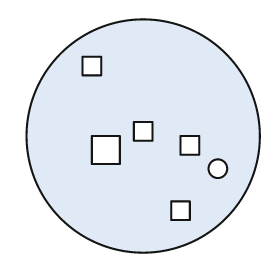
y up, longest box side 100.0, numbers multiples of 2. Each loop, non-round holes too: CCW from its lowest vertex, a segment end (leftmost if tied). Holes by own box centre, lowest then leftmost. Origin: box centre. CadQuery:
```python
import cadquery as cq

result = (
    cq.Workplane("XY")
    .moveTo(0.0, 0.0)
    .circle(50.0)
    .moveTo(12.0, -36.0)
    .lineTo(20.0, -36.0)
    .lineTo(20.0, -28.0)
    .lineTo(12.0, -28.0)
    .close()
    .moveTo(32.0, -14.0)
    .circle(4.0)
    .moveTo(-22.0, -12.0)
    .lineTo(-10.0, -12.0)
    .lineTo(-10.0, 0.0)
    .lineTo(-22.0, 0.0)
    .close()
    .moveTo(16.0, -8.0)
    .lineTo(24.0, -8.0)
    .lineTo(24.0, 0.0)
    .lineTo(16.0, 0.0)
    .close()
    .moveTo(-4.0, -2.0)
    .lineTo(4.0, -2.0)
    .lineTo(4.0, 6.0)
    .lineTo(-4.0, 6.0)
    .close()
    .moveTo(-26.0, 26.0)
    .lineTo(-18.0, 26.0)
    .lineTo(-18.0, 34.0)
    .lineTo(-26.0, 34.0)
    .close()
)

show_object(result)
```